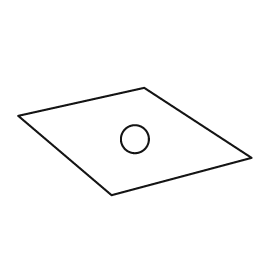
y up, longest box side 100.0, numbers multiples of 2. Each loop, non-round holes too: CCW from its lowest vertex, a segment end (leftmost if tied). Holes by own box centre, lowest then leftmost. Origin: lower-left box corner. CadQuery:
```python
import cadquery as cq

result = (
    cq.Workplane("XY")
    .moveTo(40.0, 0.0)
    .lineTo(100.0, 16.0)
    .lineTo(54.0, 46.0)
    .lineTo(0.0, 34.0)
    .close()
    .moveTo(50.0, 24.0)
    .circle(6.0)
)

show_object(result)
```